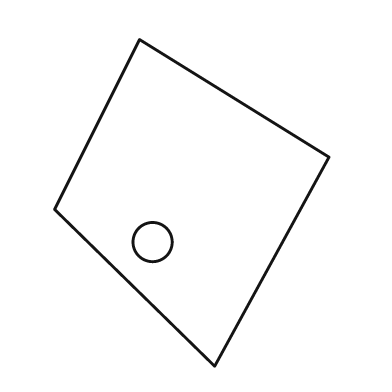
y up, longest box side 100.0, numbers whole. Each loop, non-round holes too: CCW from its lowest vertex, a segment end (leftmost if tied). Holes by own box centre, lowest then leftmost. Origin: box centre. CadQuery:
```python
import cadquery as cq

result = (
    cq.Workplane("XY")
    .moveTo(7.0, -50.0)
    .lineTo(42.0, 14.0)
    .lineTo(-16.0, 50.0)
    .lineTo(-42.0, -2.0)
    .close()
    .moveTo(-12.0, -12.0)
    .circle(6.0)
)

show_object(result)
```